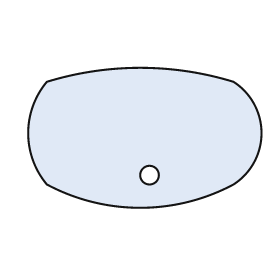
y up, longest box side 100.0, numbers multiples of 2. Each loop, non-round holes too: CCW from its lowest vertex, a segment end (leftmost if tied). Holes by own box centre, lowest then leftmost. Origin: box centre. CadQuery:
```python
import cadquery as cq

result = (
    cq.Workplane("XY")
    .moveTo(-42.0, -20.0)
    .threePointArc((-2.0, -30.0), (38.0, -20.0))
    .threePointArc((50.0, 2.0), (38.0, 24.0))
    .threePointArc((-2.0, 30.0), (-42.0, 24.0))
    .threePointArc((-50.0, 2.0), (-42.0, -20.0))
    .close()
    .moveTo(2.0, -16.0)
    .circle(4.0)
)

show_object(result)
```